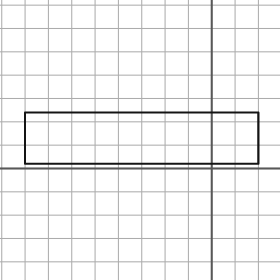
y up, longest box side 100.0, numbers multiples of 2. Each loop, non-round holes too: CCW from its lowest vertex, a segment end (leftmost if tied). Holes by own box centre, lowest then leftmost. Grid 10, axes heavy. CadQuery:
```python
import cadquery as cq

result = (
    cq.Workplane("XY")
    .moveTo(-80.0, 2.0)
    .lineTo(20.0, 2.0)
    .lineTo(20.0, 24.0)
    .lineTo(-80.0, 24.0)
    .close()
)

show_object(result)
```